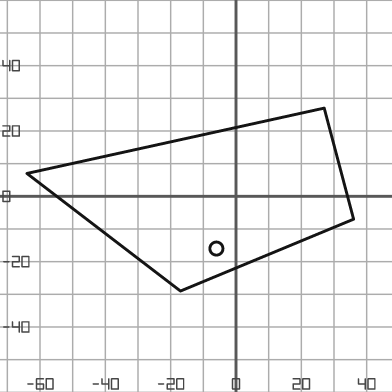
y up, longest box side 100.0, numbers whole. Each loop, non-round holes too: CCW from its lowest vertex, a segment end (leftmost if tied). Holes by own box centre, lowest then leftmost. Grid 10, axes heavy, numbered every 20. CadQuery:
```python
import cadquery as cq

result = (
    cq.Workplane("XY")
    .moveTo(-17.0, -29.0)
    .lineTo(36.0, -7.0)
    .lineTo(27.0, 27.0)
    .lineTo(-64.0, 7.0)
    .close()
    .moveTo(-6.0, -16.0)
    .circle(2.0)
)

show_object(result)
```